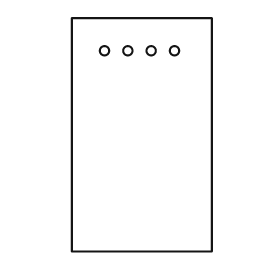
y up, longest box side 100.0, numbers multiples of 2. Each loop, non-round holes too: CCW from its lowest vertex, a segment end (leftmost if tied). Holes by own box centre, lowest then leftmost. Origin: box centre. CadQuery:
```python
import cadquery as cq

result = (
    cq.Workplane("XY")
    .moveTo(-30.0, -50.0)
    .lineTo(30.0, -50.0)
    .lineTo(30.0, 50.0)
    .lineTo(-30.0, 50.0)
    .close()
    .moveTo(-16.0, 36.0)
    .circle(2.0)
    .moveTo(-6.0, 36.0)
    .circle(2.0)
    .moveTo(4.0, 36.0)
    .circle(2.0)
    .moveTo(14.0, 36.0)
    .circle(2.0)
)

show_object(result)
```